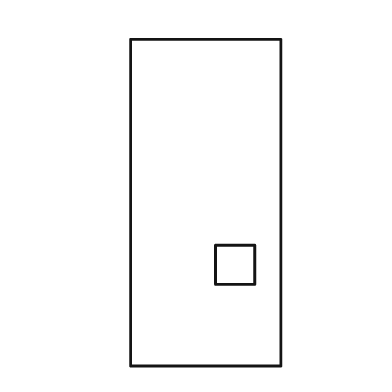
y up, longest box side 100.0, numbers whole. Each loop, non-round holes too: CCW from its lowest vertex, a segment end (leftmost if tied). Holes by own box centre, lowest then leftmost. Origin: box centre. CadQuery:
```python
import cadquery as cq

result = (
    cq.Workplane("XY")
    .moveTo(-23.0, -50.0)
    .lineTo(23.0, -50.0)
    .lineTo(23.0, 50.0)
    .lineTo(-23.0, 50.0)
    .close()
    .moveTo(3.0, -25.0)
    .lineTo(15.0, -25.0)
    .lineTo(15.0, -13.0)
    .lineTo(3.0, -13.0)
    .close()
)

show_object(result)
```